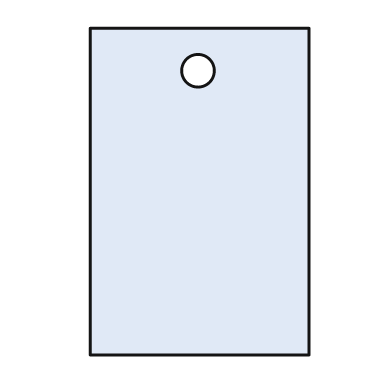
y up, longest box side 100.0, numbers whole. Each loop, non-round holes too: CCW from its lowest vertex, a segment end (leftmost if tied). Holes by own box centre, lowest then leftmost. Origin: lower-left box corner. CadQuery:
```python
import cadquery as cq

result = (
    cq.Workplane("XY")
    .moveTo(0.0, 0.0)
    .lineTo(67.0, 0.0)
    .lineTo(67.0, 100.0)
    .lineTo(0.0, 100.0)
    .close()
    .moveTo(33.0, 87.0)
    .circle(5.0)
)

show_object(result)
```